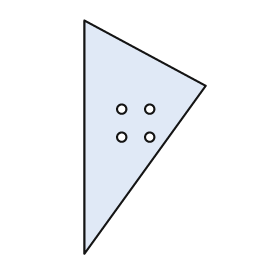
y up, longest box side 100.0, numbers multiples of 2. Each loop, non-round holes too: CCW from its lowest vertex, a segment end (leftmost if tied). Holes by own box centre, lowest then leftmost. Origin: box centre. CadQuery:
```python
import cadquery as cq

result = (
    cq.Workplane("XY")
    .moveTo(-26.0, -50.0)
    .lineTo(26.0, 22.0)
    .lineTo(-26.0, 50.0)
    .close()
    .moveTo(-10.0, 0.0)
    .circle(2.0)
    .moveTo(2.0, 0.0)
    .circle(2.0)
    .moveTo(-10.0, 12.0)
    .circle(2.0)
    .moveTo(2.0, 12.0)
    .circle(2.0)
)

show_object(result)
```